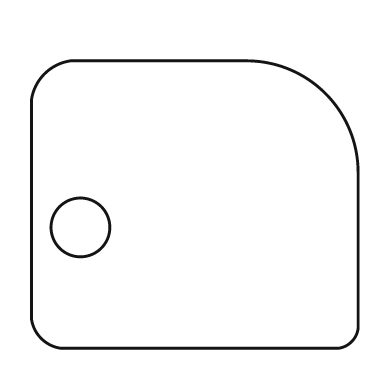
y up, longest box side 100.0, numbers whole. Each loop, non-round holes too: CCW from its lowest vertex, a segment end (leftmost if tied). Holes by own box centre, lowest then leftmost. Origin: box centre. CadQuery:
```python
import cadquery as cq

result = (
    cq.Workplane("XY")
    .moveTo(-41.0, -44.0)
    .lineTo(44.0, -44.0)
    .threePointArc((48.0, -42.0), (50.0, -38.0))
    .lineTo(50.0, 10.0)
    .threePointArc((40.0, 34.0), (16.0, 44.0))
    .lineTo(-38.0, 44.0)
    .threePointArc((-46.0, 40.0), (-50.0, 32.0))
    .lineTo(-50.0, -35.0)
    .threePointArc((-47.0, -41.0), (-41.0, -44.0))
    .close()
    .moveTo(-35.0, -7.0)
    .circle(9.0)
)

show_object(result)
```